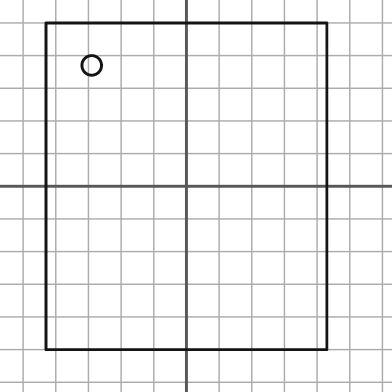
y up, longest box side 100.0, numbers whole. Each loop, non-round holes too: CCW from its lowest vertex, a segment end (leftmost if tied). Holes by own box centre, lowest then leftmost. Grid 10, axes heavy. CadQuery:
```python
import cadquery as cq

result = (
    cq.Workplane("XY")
    .moveTo(-43.0, -50.0)
    .lineTo(43.0, -50.0)
    .lineTo(43.0, 50.0)
    .lineTo(-43.0, 50.0)
    .close()
    .moveTo(-29.0, 37.0)
    .circle(3.0)
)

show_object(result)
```